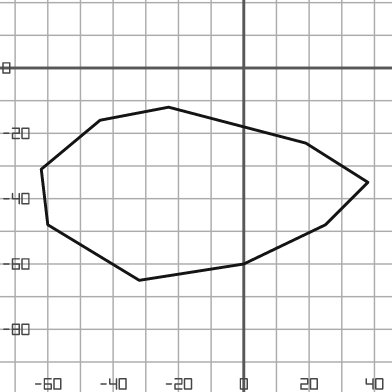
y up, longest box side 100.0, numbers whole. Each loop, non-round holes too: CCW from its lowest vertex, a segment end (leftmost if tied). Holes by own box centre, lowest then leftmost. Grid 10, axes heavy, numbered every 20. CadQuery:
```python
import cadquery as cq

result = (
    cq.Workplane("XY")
    .moveTo(-32.0, -65.0)
    .lineTo(0.0, -60.0)
    .lineTo(25.0, -48.0)
    .lineTo(38.0, -35.0)
    .lineTo(19.0, -23.0)
    .lineTo(-23.0, -12.0)
    .lineTo(-44.0, -16.0)
    .lineTo(-62.0, -31.0)
    .lineTo(-60.0, -48.0)
    .close()
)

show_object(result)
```